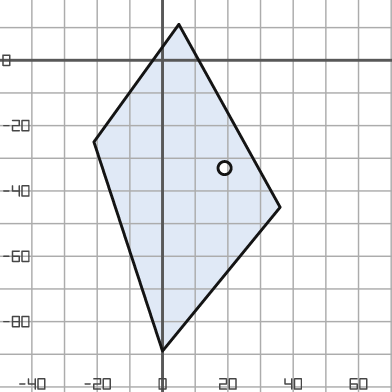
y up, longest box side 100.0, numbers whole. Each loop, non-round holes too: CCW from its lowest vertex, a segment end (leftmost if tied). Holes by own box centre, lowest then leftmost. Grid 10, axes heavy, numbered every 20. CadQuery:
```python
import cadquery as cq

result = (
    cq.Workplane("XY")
    .moveTo(0.0, -89.0)
    .lineTo(36.0, -45.0)
    .lineTo(5.0, 11.0)
    .lineTo(-21.0, -25.0)
    .close()
    .moveTo(19.0, -33.0)
    .circle(2.0)
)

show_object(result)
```